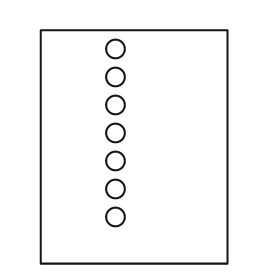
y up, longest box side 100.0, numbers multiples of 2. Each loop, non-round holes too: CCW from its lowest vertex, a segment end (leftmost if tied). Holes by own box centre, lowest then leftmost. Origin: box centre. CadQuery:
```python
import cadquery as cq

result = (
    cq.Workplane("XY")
    .moveTo(-40.0, -50.0)
    .lineTo(40.0, -50.0)
    .lineTo(40.0, 50.0)
    .lineTo(-40.0, 50.0)
    .close()
    .moveTo(-8.0, -30.0)
    .circle(4.0)
    .moveTo(-8.0, -18.0)
    .circle(4.0)
    .moveTo(-8.0, -6.0)
    .circle(4.0)
    .moveTo(-8.0, 6.0)
    .circle(4.0)
    .moveTo(-8.0, 18.0)
    .circle(4.0)
    .moveTo(-8.0, 30.0)
    .circle(4.0)
    .moveTo(-8.0, 42.0)
    .circle(4.0)
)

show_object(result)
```